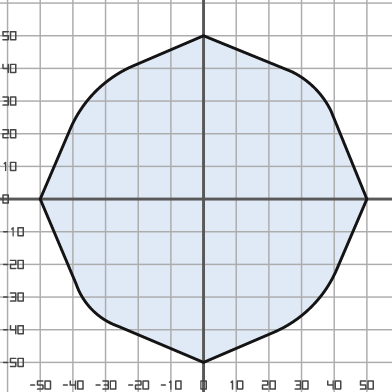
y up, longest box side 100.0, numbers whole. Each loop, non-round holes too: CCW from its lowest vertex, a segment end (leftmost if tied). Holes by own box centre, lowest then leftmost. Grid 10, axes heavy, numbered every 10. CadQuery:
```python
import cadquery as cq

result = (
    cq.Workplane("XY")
    .moveTo(0.0, -50.0)
    .lineTo(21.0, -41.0)
    .threePointArc((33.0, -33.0), (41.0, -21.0))
    .lineTo(50.0, 0.0)
    .lineTo(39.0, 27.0)
    .threePointArc((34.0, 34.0), (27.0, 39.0))
    .lineTo(0.0, 50.0)
    .lineTo(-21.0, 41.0)
    .threePointArc((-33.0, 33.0), (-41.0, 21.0))
    .lineTo(-50.0, 0.0)
    .lineTo(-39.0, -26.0)
    .threePointArc((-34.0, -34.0), (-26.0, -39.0))
    .close()
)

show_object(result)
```